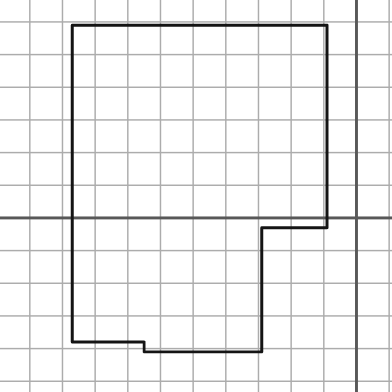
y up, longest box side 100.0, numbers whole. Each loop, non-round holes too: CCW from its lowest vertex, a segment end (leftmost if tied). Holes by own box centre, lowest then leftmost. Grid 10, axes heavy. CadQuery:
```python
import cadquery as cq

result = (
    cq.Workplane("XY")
    .moveTo(-65.0, -41.0)
    .lineTo(-29.0, -41.0)
    .lineTo(-29.0, -3.0)
    .lineTo(-9.0, -3.0)
    .lineTo(-9.0, 59.0)
    .lineTo(-87.0, 59.0)
    .lineTo(-87.0, -38.0)
    .lineTo(-65.0, -38.0)
    .close()
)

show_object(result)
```